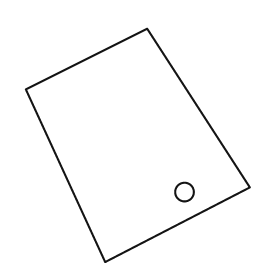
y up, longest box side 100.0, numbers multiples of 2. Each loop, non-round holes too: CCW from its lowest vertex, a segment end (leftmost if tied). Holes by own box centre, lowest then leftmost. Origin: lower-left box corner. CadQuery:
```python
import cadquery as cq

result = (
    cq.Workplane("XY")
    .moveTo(34.0, 0.0)
    .lineTo(96.0, 32.0)
    .lineTo(52.0, 100.0)
    .lineTo(0.0, 74.0)
    .close()
    .moveTo(68.0, 30.0)
    .circle(4.0)
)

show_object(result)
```